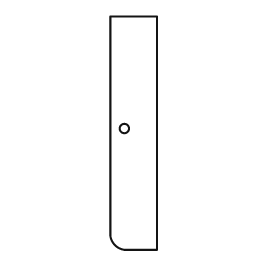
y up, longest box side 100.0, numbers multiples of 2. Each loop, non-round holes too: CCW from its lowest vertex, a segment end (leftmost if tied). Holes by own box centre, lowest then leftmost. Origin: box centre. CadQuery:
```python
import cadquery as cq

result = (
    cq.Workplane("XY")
    .moveTo(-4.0, -50.0)
    .lineTo(10.0, -50.0)
    .lineTo(10.0, 50.0)
    .lineTo(-10.0, 50.0)
    .lineTo(-10.0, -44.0)
    .threePointArc((-8.0, -48.0), (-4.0, -50.0))
    .close()
    .moveTo(-4.0, 2.0)
    .circle(2.0)
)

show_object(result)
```